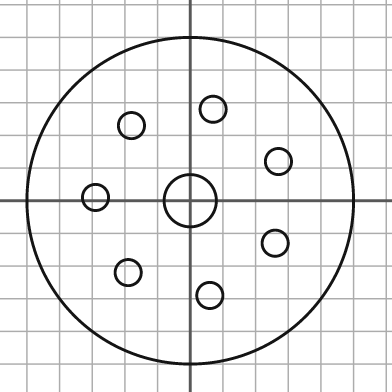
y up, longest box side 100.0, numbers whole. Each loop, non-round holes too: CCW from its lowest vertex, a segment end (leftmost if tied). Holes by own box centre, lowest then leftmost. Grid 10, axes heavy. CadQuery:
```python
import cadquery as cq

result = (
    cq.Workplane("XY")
    .moveTo(0.0, 0.0)
    .circle(50.0)
    .moveTo(6.0, -29.0)
    .circle(4.0)
    .moveTo(-19.0, -22.0)
    .circle(4.0)
    .moveTo(26.0, -13.0)
    .circle(4.0)
    .moveTo(0.0, 0.0)
    .circle(8.0)
    .moveTo(-29.0, 1.0)
    .circle(4.0)
    .moveTo(27.0, 12.0)
    .circle(4.0)
    .moveTo(-18.0, 23.0)
    .circle(4.0)
    .moveTo(7.0, 28.0)
    .circle(4.0)
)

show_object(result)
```